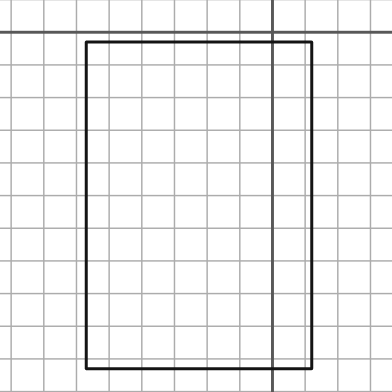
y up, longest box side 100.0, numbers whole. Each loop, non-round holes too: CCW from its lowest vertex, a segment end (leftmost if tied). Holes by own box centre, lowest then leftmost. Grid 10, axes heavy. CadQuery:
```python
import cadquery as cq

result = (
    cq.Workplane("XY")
    .moveTo(-57.0, -103.0)
    .lineTo(12.0, -103.0)
    .lineTo(12.0, -3.0)
    .lineTo(-57.0, -3.0)
    .close()
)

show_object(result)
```